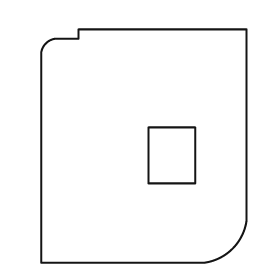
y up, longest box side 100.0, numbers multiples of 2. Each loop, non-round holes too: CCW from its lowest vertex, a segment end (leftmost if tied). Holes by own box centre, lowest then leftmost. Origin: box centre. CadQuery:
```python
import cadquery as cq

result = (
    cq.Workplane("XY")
    .moveTo(-44.0, -50.0)
    .lineTo(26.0, -50.0)
    .threePointArc((38.0, -44.0), (44.0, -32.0))
    .lineTo(44.0, 50.0)
    .lineTo(-28.0, 50.0)
    .lineTo(-28.0, 46.0)
    .lineTo(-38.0, 46.0)
    .threePointArc((-42.0, 44.0), (-44.0, 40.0))
    .close()
    .moveTo(2.0, -16.0)
    .lineTo(22.0, -16.0)
    .lineTo(22.0, 8.0)
    .lineTo(2.0, 8.0)
    .close()
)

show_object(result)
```